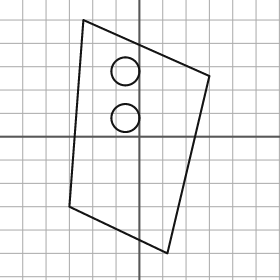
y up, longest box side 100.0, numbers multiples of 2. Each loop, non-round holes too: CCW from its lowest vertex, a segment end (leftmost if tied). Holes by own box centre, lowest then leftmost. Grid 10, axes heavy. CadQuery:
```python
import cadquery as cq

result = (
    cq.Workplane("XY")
    .moveTo(12.0, -50.0)
    .lineTo(30.0, 26.0)
    .lineTo(-24.0, 50.0)
    .lineTo(-30.0, -30.0)
    .close()
    .moveTo(-6.0, 8.0)
    .circle(6.0)
    .moveTo(-6.0, 28.0)
    .circle(6.0)
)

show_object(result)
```